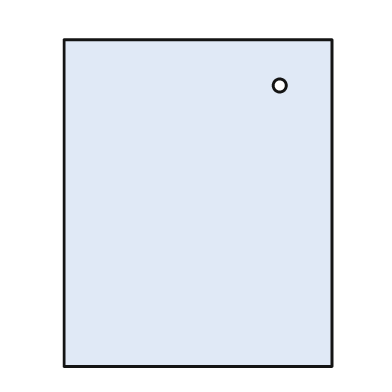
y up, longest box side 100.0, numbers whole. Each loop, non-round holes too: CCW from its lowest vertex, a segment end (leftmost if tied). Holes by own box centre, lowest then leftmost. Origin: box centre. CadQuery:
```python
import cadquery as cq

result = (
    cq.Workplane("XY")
    .moveTo(-41.0, -50.0)
    .lineTo(41.0, -50.0)
    .lineTo(41.0, 50.0)
    .lineTo(-41.0, 50.0)
    .close()
    .moveTo(25.0, 36.0)
    .circle(2.0)
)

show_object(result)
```